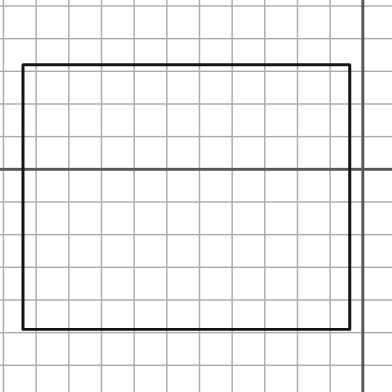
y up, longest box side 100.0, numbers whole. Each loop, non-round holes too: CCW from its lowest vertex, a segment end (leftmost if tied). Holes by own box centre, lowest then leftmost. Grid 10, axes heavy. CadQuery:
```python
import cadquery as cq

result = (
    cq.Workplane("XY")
    .moveTo(-104.0, -49.0)
    .lineTo(-4.0, -49.0)
    .lineTo(-4.0, 32.0)
    .lineTo(-104.0, 32.0)
    .close()
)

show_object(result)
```